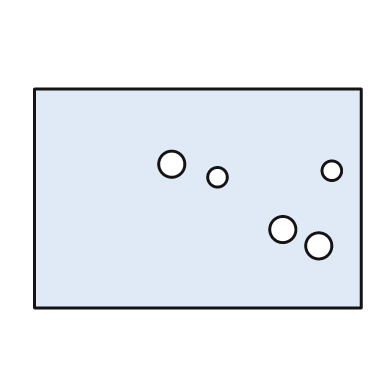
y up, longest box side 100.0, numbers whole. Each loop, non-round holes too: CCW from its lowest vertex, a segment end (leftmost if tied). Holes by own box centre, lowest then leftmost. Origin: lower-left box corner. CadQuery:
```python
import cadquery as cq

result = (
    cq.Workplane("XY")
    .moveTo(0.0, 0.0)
    .lineTo(100.0, 0.0)
    .lineTo(100.0, 67.0)
    .lineTo(0.0, 67.0)
    .close()
    .moveTo(87.0, 19.0)
    .circle(4.0)
    .moveTo(76.0, 24.0)
    .circle(4.0)
    .moveTo(56.0, 40.0)
    .circle(3.0)
    .moveTo(91.0, 42.0)
    .circle(3.0)
    .moveTo(42.0, 44.0)
    .circle(4.0)
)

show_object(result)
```